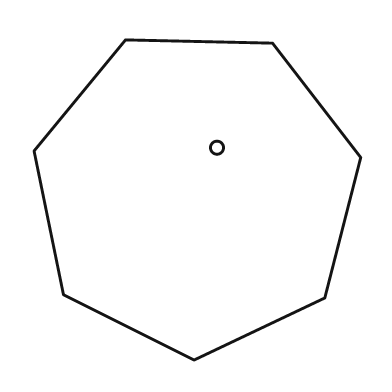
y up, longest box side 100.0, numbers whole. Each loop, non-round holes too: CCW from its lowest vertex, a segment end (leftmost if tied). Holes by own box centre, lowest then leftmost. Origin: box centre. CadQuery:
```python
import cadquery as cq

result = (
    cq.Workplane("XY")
    .moveTo(-1.0, -49.0)
    .lineTo(39.0, -30.0)
    .lineTo(50.0, 13.0)
    .lineTo(23.0, 48.0)
    .lineTo(-22.0, 49.0)
    .lineTo(-50.0, 15.0)
    .lineTo(-41.0, -29.0)
    .close()
    .moveTo(6.0, 16.0)
    .circle(2.0)
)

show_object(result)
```